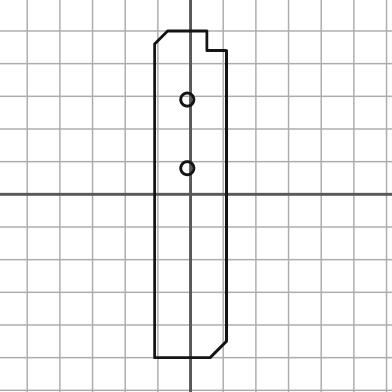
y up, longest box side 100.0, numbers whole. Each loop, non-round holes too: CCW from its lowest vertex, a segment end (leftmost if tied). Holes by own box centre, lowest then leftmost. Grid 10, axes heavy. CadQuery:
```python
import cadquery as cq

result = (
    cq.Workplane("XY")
    .moveTo(-11.0, -50.0)
    .lineTo(6.0, -50.0)
    .lineTo(11.0, -45.0)
    .lineTo(11.0, 44.0)
    .lineTo(5.0, 44.0)
    .lineTo(5.0, 50.0)
    .lineTo(-7.0, 50.0)
    .lineTo(-11.0, 46.0)
    .close()
    .moveTo(-1.0, 8.0)
    .circle(2.0)
    .moveTo(-1.0, 29.0)
    .circle(2.0)
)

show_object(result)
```